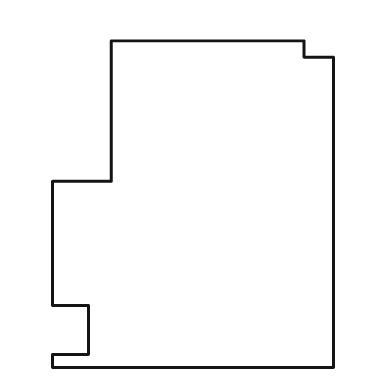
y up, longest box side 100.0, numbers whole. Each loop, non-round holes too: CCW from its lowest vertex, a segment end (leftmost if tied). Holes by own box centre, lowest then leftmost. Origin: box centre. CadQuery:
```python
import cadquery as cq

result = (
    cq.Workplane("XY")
    .moveTo(-43.0, -50.0)
    .lineTo(43.0, -50.0)
    .lineTo(43.0, 45.0)
    .lineTo(34.0, 45.0)
    .lineTo(34.0, 50.0)
    .lineTo(-25.0, 50.0)
    .lineTo(-25.0, 7.0)
    .lineTo(-43.0, 7.0)
    .lineTo(-43.0, -31.0)
    .lineTo(-32.0, -31.0)
    .lineTo(-32.0, -46.0)
    .lineTo(-43.0, -46.0)
    .close()
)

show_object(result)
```